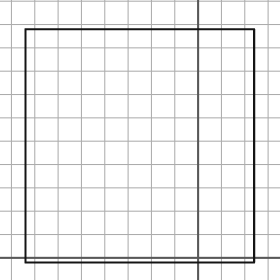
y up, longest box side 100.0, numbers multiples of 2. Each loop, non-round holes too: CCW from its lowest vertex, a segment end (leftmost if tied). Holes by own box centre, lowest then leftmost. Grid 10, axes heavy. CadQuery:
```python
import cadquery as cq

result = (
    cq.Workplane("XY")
    .moveTo(-74.0, -2.0)
    .lineTo(24.0, -2.0)
    .lineTo(24.0, 98.0)
    .lineTo(-74.0, 98.0)
    .close()
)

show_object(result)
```